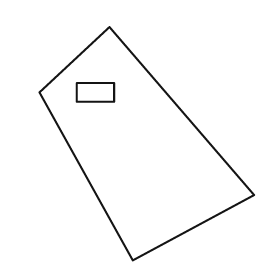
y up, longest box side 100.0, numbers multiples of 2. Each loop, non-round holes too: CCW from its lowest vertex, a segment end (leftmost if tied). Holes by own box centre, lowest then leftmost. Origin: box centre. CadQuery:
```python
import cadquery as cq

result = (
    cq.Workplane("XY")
    .moveTo(-6.0, -50.0)
    .lineTo(46.0, -22.0)
    .lineTo(-16.0, 50.0)
    .lineTo(-46.0, 22.0)
    .close()
    .moveTo(-30.0, 18.0)
    .lineTo(-14.0, 18.0)
    .lineTo(-14.0, 26.0)
    .lineTo(-30.0, 26.0)
    .close()
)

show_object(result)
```